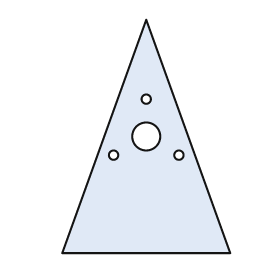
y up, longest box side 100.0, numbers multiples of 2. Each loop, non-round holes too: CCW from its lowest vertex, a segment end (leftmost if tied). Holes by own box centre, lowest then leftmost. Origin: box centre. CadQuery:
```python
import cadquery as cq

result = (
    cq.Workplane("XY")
    .moveTo(-36.0, -50.0)
    .lineTo(36.0, -50.0)
    .lineTo(0.0, 50.0)
    .close()
    .moveTo(-14.0, -8.0)
    .circle(2.0)
    .moveTo(14.0, -8.0)
    .circle(2.0)
    .moveTo(0.0, 0.0)
    .circle(6.0)
    .moveTo(0.0, 16.0)
    .circle(2.0)
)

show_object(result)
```